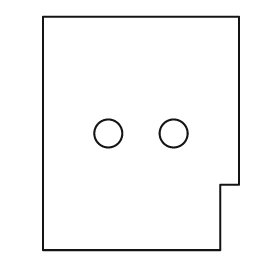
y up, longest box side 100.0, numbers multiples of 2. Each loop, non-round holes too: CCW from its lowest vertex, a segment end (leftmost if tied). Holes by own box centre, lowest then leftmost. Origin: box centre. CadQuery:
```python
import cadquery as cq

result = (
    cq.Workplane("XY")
    .moveTo(-42.0, -50.0)
    .lineTo(34.0, -50.0)
    .lineTo(34.0, -22.0)
    .lineTo(42.0, -22.0)
    .lineTo(42.0, 50.0)
    .lineTo(-42.0, 50.0)
    .close()
    .moveTo(-14.0, 0.0)
    .circle(6.0)
    .moveTo(14.0, 0.0)
    .circle(6.0)
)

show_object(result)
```